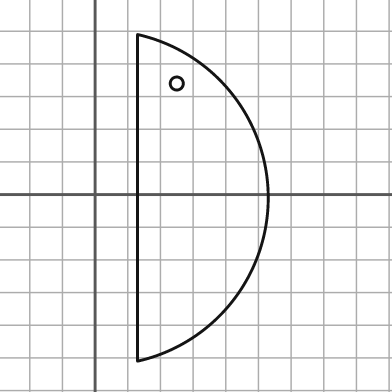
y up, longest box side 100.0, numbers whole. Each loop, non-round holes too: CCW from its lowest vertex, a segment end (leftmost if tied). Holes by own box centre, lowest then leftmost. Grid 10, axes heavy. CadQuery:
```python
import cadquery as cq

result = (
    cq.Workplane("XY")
    .moveTo(13.0, -51.0)
    .threePointArc((53.0, -1.0), (13.0, 49.0))
    .close()
    .moveTo(25.0, 34.0)
    .circle(2.0)
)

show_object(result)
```